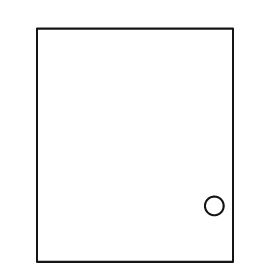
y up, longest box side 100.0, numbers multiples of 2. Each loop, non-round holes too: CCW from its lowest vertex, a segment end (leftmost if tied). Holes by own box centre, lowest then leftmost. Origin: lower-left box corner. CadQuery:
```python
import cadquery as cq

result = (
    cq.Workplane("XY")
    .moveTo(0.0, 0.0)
    .lineTo(84.0, 0.0)
    .lineTo(84.0, 100.0)
    .lineTo(0.0, 100.0)
    .close()
    .moveTo(76.0, 24.0)
    .circle(4.0)
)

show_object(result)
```